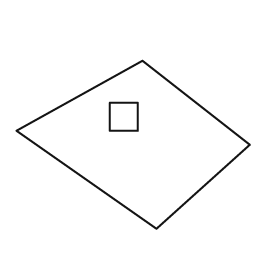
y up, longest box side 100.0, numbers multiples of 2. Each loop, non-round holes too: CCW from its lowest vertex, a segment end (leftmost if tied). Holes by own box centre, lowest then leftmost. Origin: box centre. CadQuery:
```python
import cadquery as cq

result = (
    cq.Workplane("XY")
    .moveTo(10.0, -36.0)
    .lineTo(50.0, 0.0)
    .lineTo(4.0, 36.0)
    .lineTo(-50.0, 6.0)
    .close()
    .moveTo(-10.0, 6.0)
    .lineTo(2.0, 6.0)
    .lineTo(2.0, 18.0)
    .lineTo(-10.0, 18.0)
    .close()
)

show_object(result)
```